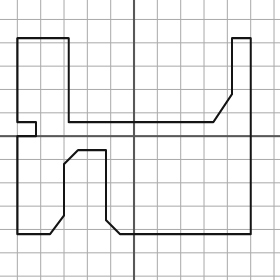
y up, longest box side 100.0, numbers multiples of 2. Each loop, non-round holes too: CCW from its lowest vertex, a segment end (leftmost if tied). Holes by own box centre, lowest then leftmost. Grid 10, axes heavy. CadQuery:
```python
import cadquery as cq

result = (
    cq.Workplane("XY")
    .moveTo(-50.0, -42.0)
    .lineTo(-36.0, -42.0)
    .lineTo(-30.0, -34.0)
    .lineTo(-30.0, -12.0)
    .lineTo(-24.0, -6.0)
    .lineTo(-12.0, -6.0)
    .lineTo(-12.0, -36.0)
    .lineTo(-6.0, -42.0)
    .lineTo(50.0, -42.0)
    .lineTo(50.0, 42.0)
    .lineTo(42.0, 42.0)
    .lineTo(42.0, 18.0)
    .lineTo(34.0, 6.0)
    .lineTo(-28.0, 6.0)
    .lineTo(-28.0, 42.0)
    .lineTo(-50.0, 42.0)
    .lineTo(-50.0, 6.0)
    .lineTo(-42.0, 6.0)
    .lineTo(-42.0, 0.0)
    .lineTo(-50.0, 0.0)
    .close()
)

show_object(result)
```